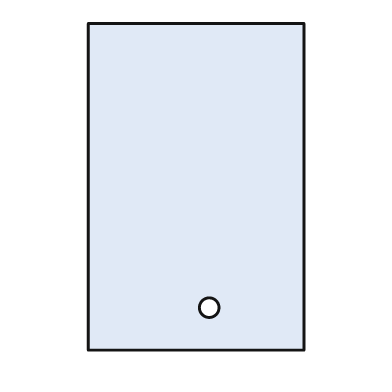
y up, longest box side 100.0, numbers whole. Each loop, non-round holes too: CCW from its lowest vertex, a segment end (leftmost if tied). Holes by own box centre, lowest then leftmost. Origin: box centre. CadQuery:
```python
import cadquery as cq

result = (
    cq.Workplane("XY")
    .moveTo(-33.0, -50.0)
    .lineTo(33.0, -50.0)
    .lineTo(33.0, 50.0)
    .lineTo(-33.0, 50.0)
    .close()
    .moveTo(4.0, -37.0)
    .circle(3.0)
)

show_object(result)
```